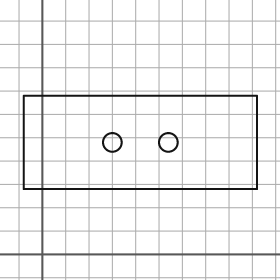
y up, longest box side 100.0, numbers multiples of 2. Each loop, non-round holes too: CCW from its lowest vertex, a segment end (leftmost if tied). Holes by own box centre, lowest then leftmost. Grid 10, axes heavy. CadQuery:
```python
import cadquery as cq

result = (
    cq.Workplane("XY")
    .moveTo(-8.0, 28.0)
    .lineTo(92.0, 28.0)
    .lineTo(92.0, 68.0)
    .lineTo(-8.0, 68.0)
    .close()
    .moveTo(30.0, 48.0)
    .circle(4.0)
    .moveTo(54.0, 48.0)
    .circle(4.0)
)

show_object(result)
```